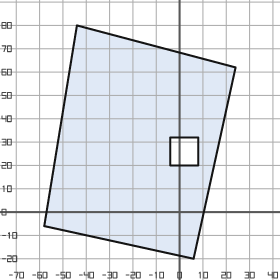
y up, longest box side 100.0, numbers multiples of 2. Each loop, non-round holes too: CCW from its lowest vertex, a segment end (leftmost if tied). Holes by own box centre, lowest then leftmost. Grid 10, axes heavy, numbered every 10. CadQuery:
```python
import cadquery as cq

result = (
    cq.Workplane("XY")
    .moveTo(6.0, -20.0)
    .lineTo(24.0, 62.0)
    .lineTo(-44.0, 80.0)
    .lineTo(-58.0, -6.0)
    .close()
    .moveTo(-4.0, 20.0)
    .lineTo(8.0, 20.0)
    .lineTo(8.0, 32.0)
    .lineTo(-4.0, 32.0)
    .close()
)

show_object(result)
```